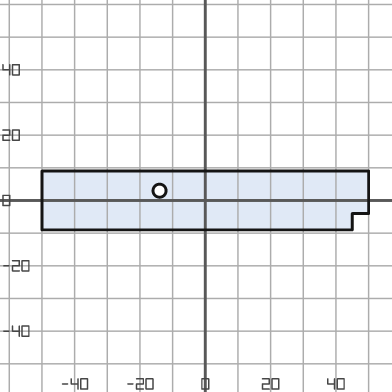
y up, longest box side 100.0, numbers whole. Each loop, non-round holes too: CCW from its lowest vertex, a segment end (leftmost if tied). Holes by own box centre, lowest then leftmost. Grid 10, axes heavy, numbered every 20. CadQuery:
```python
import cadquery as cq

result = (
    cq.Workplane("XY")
    .moveTo(-50.0, -9.0)
    .lineTo(45.0, -9.0)
    .lineTo(45.0, -4.0)
    .lineTo(50.0, -4.0)
    .lineTo(50.0, 9.0)
    .lineTo(-50.0, 9.0)
    .close()
    .moveTo(-14.0, 3.0)
    .circle(2.0)
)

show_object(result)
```